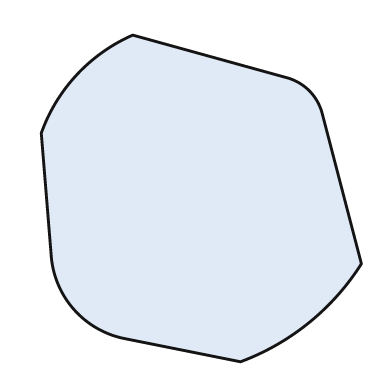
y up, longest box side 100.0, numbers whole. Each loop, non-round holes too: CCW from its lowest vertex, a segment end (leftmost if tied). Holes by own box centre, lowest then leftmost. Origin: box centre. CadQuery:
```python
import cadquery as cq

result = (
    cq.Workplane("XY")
    .moveTo(12.0, -50.0)
    .threePointArc((33.0, -38.0), (49.0, -20.0))
    .lineTo(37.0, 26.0)
    .threePointArc((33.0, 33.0), (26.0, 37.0))
    .lineTo(-21.0, 50.0)
    .threePointArc((-38.0, 38.0), (-49.0, 20.0))
    .lineTo(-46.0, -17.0)
    .threePointArc((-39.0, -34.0), (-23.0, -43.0))
    .close()
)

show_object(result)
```